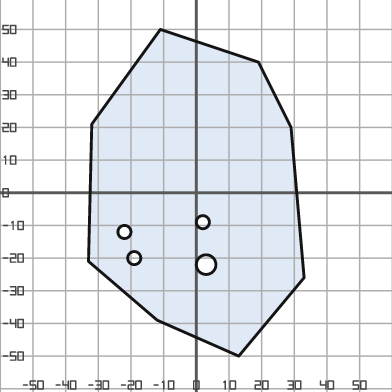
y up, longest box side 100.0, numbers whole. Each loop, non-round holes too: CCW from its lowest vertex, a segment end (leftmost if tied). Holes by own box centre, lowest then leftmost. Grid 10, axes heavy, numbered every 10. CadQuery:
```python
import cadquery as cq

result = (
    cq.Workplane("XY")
    .moveTo(13.0, -50.0)
    .lineTo(33.0, -26.0)
    .lineTo(29.0, 20.0)
    .lineTo(19.0, 40.0)
    .lineTo(-11.0, 50.0)
    .lineTo(-32.0, 21.0)
    .lineTo(-33.0, -21.0)
    .lineTo(-12.0, -39.0)
    .close()
    .moveTo(3.0, -22.0)
    .circle(3.0)
    .moveTo(-19.0, -20.0)
    .circle(2.0)
    .moveTo(-22.0, -12.0)
    .circle(2.0)
    .moveTo(2.0, -9.0)
    .circle(2.0)
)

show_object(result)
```